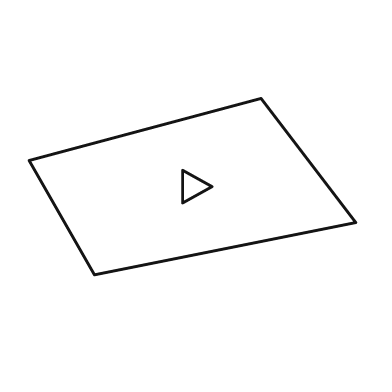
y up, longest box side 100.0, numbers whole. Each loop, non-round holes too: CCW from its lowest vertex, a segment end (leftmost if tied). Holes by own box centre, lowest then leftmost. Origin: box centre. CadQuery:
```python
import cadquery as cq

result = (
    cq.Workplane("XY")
    .moveTo(-30.0, -27.0)
    .lineTo(50.0, -11.0)
    .lineTo(21.0, 27.0)
    .lineTo(-50.0, 8.0)
    .close()
    .moveTo(-3.0, -5.0)
    .lineTo(6.0, 0.0)
    .lineTo(-3.0, 5.0)
    .close()
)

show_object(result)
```